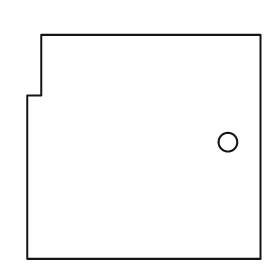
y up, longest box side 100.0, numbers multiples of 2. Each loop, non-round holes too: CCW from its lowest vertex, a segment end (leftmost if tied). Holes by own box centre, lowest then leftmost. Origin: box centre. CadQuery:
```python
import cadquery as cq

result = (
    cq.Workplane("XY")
    .moveTo(-50.0, -48.0)
    .lineTo(50.0, -48.0)
    .lineTo(50.0, 48.0)
    .lineTo(-44.0, 48.0)
    .lineTo(-44.0, 22.0)
    .lineTo(-50.0, 22.0)
    .close()
    .moveTo(36.0, 2.0)
    .circle(4.0)
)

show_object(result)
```